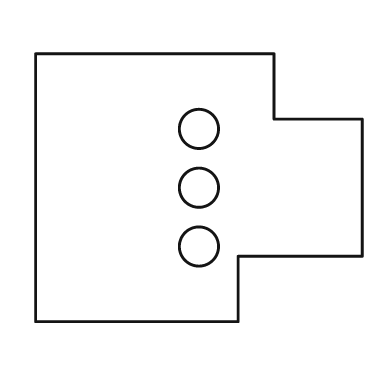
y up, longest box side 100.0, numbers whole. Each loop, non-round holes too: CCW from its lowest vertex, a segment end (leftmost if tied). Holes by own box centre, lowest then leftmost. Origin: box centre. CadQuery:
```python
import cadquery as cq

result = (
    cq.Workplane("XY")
    .moveTo(-50.0, -41.0)
    .lineTo(12.0, -41.0)
    .lineTo(12.0, -21.0)
    .lineTo(50.0, -21.0)
    .lineTo(50.0, 21.0)
    .lineTo(23.0, 21.0)
    .lineTo(23.0, 41.0)
    .lineTo(-50.0, 41.0)
    .close()
    .moveTo(0.0, -18.0)
    .circle(6.0)
    .moveTo(0.0, 0.0)
    .circle(6.0)
    .moveTo(0.0, 18.0)
    .circle(6.0)
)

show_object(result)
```